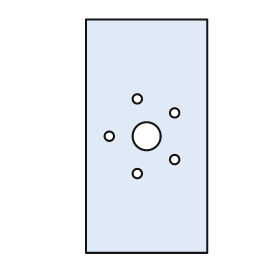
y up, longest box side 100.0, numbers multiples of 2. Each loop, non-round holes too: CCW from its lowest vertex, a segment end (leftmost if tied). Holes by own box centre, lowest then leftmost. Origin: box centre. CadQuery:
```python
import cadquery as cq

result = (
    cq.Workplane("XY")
    .moveTo(-26.0, -50.0)
    .lineTo(26.0, -50.0)
    .lineTo(26.0, 50.0)
    .lineTo(-26.0, 50.0)
    .close()
    .moveTo(-4.0, -16.0)
    .circle(2.0)
    .moveTo(12.0, -10.0)
    .circle(2.0)
    .moveTo(-16.0, 0.0)
    .circle(2.0)
    .moveTo(0.0, 0.0)
    .circle(6.0)
    .moveTo(12.0, 10.0)
    .circle(2.0)
    .moveTo(-4.0, 16.0)
    .circle(2.0)
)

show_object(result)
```